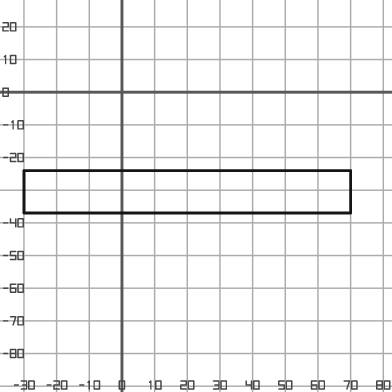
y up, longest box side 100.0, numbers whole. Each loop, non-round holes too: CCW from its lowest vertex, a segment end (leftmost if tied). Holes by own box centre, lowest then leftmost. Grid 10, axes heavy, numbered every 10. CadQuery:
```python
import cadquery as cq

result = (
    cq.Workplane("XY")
    .moveTo(-30.0, -37.0)
    .lineTo(70.0, -37.0)
    .lineTo(70.0, -24.0)
    .lineTo(-30.0, -24.0)
    .close()
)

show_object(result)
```